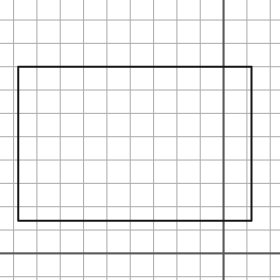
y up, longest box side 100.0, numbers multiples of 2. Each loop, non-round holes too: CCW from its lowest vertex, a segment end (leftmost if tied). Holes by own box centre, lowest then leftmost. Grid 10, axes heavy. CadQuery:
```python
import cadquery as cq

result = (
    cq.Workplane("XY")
    .moveTo(-88.0, 14.0)
    .lineTo(12.0, 14.0)
    .lineTo(12.0, 80.0)
    .lineTo(-88.0, 80.0)
    .close()
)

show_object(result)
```